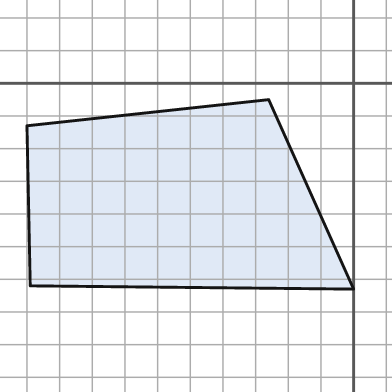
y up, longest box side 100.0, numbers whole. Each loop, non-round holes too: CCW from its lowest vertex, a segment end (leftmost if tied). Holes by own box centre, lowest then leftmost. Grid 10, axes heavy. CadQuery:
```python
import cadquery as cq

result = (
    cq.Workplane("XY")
    .moveTo(0.0, -63.0)
    .lineTo(-26.0, -5.0)
    .lineTo(-100.0, -13.0)
    .lineTo(-99.0, -62.0)
    .close()
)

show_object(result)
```